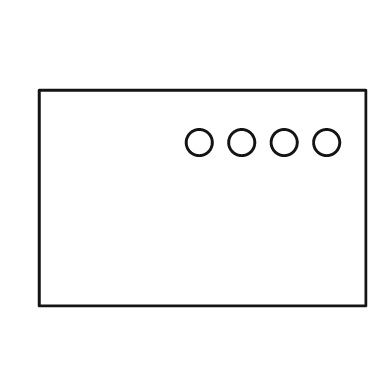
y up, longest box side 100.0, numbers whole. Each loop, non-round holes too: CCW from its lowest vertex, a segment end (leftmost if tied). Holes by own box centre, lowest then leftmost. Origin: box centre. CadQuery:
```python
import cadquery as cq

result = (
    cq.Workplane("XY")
    .moveTo(-50.0, -33.0)
    .lineTo(50.0, -33.0)
    .lineTo(50.0, 33.0)
    .lineTo(-50.0, 33.0)
    .close()
    .moveTo(-1.0, 17.0)
    .circle(4.0)
    .moveTo(12.0, 17.0)
    .circle(4.0)
    .moveTo(25.0, 17.0)
    .circle(4.0)
    .moveTo(38.0, 17.0)
    .circle(4.0)
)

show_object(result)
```